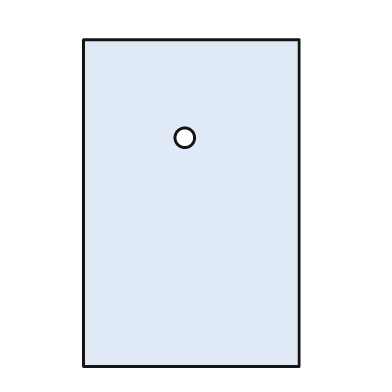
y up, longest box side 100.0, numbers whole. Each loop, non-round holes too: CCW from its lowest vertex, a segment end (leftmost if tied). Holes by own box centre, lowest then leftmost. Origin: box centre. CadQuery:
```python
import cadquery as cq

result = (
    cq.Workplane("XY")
    .moveTo(-33.0, -50.0)
    .lineTo(33.0, -50.0)
    .lineTo(33.0, 50.0)
    .lineTo(-33.0, 50.0)
    .close()
    .moveTo(-2.0, 20.0)
    .circle(3.0)
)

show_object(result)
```